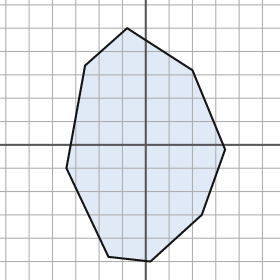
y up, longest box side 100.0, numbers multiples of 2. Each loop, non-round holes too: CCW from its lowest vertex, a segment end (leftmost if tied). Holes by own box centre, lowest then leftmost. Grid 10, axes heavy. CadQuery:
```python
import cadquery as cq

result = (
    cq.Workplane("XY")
    .moveTo(2.0, -50.0)
    .lineTo(24.0, -30.0)
    .lineTo(34.0, -2.0)
    .lineTo(20.0, 32.0)
    .lineTo(-8.0, 50.0)
    .lineTo(-26.0, 34.0)
    .lineTo(-34.0, -10.0)
    .lineTo(-16.0, -48.0)
    .close()
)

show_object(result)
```